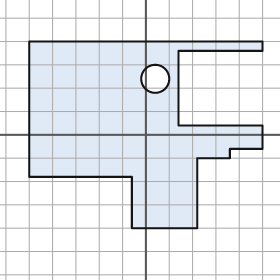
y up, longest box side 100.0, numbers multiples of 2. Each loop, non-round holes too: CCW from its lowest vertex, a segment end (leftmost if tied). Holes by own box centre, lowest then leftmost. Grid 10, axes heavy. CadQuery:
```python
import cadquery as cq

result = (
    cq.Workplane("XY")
    .moveTo(-6.0, -40.0)
    .lineTo(22.0, -40.0)
    .lineTo(22.0, -10.0)
    .lineTo(36.0, -10.0)
    .lineTo(36.0, -6.0)
    .lineTo(50.0, -6.0)
    .lineTo(50.0, 4.0)
    .lineTo(14.0, 4.0)
    .lineTo(14.0, 36.0)
    .lineTo(50.0, 36.0)
    .lineTo(50.0, 40.0)
    .lineTo(-50.0, 40.0)
    .lineTo(-50.0, -18.0)
    .lineTo(-6.0, -18.0)
    .close()
    .moveTo(4.0, 24.0)
    .circle(6.0)
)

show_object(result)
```